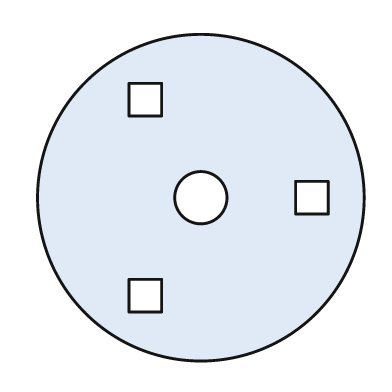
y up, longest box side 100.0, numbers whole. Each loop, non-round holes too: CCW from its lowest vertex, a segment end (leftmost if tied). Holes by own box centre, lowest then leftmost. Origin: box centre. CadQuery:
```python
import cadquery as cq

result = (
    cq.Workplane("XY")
    .moveTo(0.0, 0.0)
    .circle(50.0)
    .moveTo(-22.0, -35.0)
    .lineTo(-12.0, -35.0)
    .lineTo(-12.0, -25.0)
    .lineTo(-22.0, -25.0)
    .close()
    .moveTo(0.0, 0.0)
    .circle(8.0)
    .moveTo(29.0, -5.0)
    .lineTo(39.0, -5.0)
    .lineTo(39.0, 5.0)
    .lineTo(29.0, 5.0)
    .close()
    .moveTo(-22.0, 25.0)
    .lineTo(-12.0, 25.0)
    .lineTo(-12.0, 35.0)
    .lineTo(-22.0, 35.0)
    .close()
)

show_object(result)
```